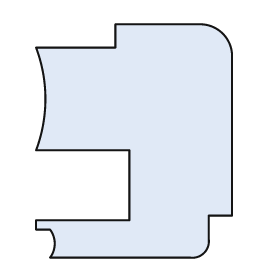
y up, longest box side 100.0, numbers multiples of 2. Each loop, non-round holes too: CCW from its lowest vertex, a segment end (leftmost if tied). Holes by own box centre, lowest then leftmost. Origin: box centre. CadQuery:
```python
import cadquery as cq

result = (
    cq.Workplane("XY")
    .moveTo(-36.0, -50.0)
    .lineTo(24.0, -50.0)
    .threePointArc((30.0, -48.0), (32.0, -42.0))
    .lineTo(32.0, -32.0)
    .lineTo(42.0, -32.0)
    .lineTo(42.0, 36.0)
    .threePointArc((38.0, 46.0), (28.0, 50.0))
    .lineTo(-8.0, 50.0)
    .lineTo(-8.0, 40.0)
    .lineTo(-42.0, 40.0)
    .threePointArc((-38.0, 18.0), (-42.0, -4.0))
    .lineTo(-2.0, -4.0)
    .lineTo(-2.0, -34.0)
    .lineTo(-42.0, -34.0)
    .lineTo(-42.0, -38.0)
    .lineTo(-36.0, -38.0)
    .threePointArc((-34.0, -44.0), (-36.0, -50.0))
    .close()
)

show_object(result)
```